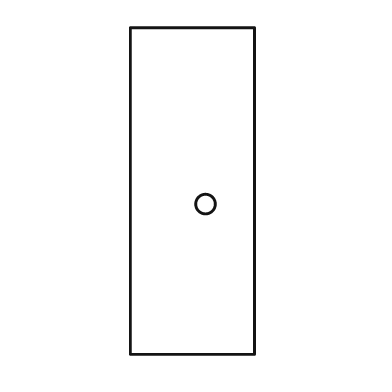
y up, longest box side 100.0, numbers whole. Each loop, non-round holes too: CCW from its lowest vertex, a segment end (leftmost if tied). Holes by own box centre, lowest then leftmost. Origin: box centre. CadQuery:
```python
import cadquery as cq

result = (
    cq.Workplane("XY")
    .moveTo(-19.0, -50.0)
    .lineTo(19.0, -50.0)
    .lineTo(19.0, 50.0)
    .lineTo(-19.0, 50.0)
    .close()
    .moveTo(4.0, -4.0)
    .circle(3.0)
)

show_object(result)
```